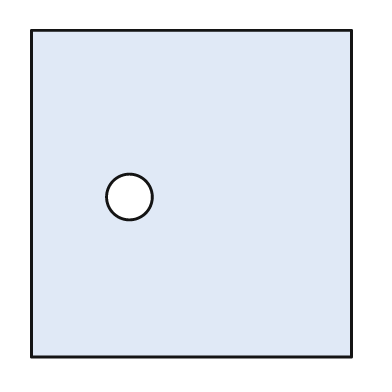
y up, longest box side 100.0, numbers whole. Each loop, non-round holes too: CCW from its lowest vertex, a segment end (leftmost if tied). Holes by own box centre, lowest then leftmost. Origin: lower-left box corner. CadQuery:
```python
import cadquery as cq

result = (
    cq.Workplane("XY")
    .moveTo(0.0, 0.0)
    .lineTo(98.0, 0.0)
    .lineTo(98.0, 100.0)
    .lineTo(0.0, 100.0)
    .close()
    .moveTo(30.0, 49.0)
    .circle(7.0)
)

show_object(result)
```